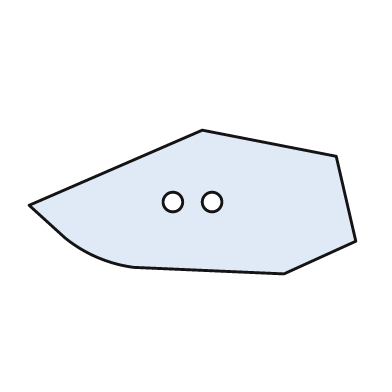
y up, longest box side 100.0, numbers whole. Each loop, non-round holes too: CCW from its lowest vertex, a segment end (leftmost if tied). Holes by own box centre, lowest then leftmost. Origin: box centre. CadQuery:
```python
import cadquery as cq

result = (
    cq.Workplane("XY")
    .moveTo(28.0, -22.0)
    .lineTo(50.0, -12.0)
    .lineTo(44.0, 14.0)
    .lineTo(3.0, 22.0)
    .lineTo(-50.0, -1.0)
    .lineTo(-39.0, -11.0)
    .threePointArc((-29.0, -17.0), (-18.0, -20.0))
    .close()
    .moveTo(-6.0, 0.0)
    .circle(3.0)
    .moveTo(6.0, 0.0)
    .circle(3.0)
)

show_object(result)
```